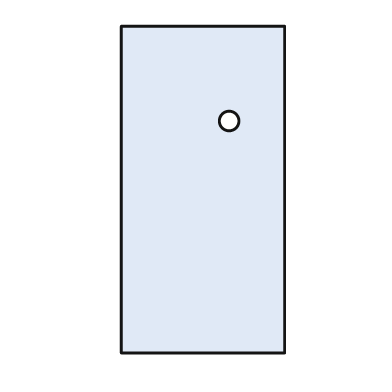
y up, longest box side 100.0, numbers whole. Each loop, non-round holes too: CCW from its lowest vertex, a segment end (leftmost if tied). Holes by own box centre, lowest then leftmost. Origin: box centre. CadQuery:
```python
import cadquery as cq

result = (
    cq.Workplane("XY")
    .moveTo(-25.0, -50.0)
    .lineTo(25.0, -50.0)
    .lineTo(25.0, 50.0)
    .lineTo(-25.0, 50.0)
    .close()
    .moveTo(8.0, 21.0)
    .circle(3.0)
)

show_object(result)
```